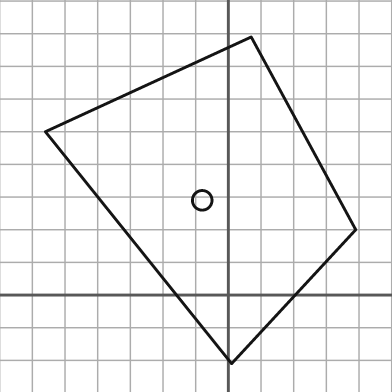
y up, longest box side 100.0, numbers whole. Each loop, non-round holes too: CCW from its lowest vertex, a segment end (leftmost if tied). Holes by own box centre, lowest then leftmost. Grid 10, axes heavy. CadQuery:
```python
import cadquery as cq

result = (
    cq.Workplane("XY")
    .moveTo(1.0, -21.0)
    .lineTo(39.0, 20.0)
    .lineTo(7.0, 79.0)
    .lineTo(-56.0, 50.0)
    .close()
    .moveTo(-8.0, 29.0)
    .circle(3.0)
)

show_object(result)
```